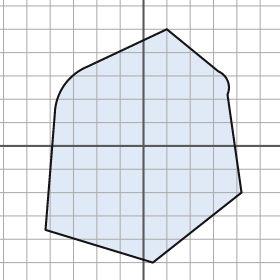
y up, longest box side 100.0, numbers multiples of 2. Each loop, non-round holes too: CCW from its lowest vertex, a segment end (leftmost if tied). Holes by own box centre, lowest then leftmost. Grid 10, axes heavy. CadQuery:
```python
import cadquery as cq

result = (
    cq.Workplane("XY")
    .moveTo(4.0, -50.0)
    .lineTo(42.0, -20.0)
    .lineTo(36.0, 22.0)
    .threePointArc((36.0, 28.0), (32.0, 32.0))
    .lineTo(10.0, 50.0)
    .lineTo(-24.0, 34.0)
    .threePointArc((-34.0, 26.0), (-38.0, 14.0))
    .lineTo(-42.0, -36.0)
    .close()
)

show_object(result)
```